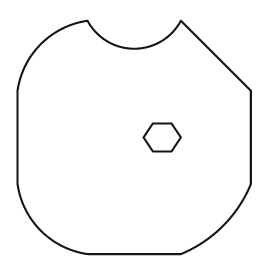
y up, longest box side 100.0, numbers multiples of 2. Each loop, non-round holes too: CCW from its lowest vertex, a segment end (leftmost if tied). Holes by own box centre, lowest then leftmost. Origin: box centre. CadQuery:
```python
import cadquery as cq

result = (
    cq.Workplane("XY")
    .moveTo(-20.0, -50.0)
    .lineTo(20.0, -50.0)
    .threePointArc((38.0, -38.0), (50.0, -20.0))
    .lineTo(50.0, 20.0)
    .lineTo(20.0, 50.0)
    .threePointArc((0.0, 38.0), (-20.0, 50.0))
    .threePointArc((-40.0, 40.0), (-50.0, 20.0))
    .lineTo(-50.0, -20.0)
    .threePointArc((-40.0, -40.0), (-20.0, -50.0))
    .close()
    .moveTo(8.0, -6.0)
    .lineTo(16.0, -6.0)
    .lineTo(20.0, 0.0)
    .lineTo(16.0, 6.0)
    .lineTo(8.0, 6.0)
    .lineTo(4.0, 0.0)
    .close()
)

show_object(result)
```